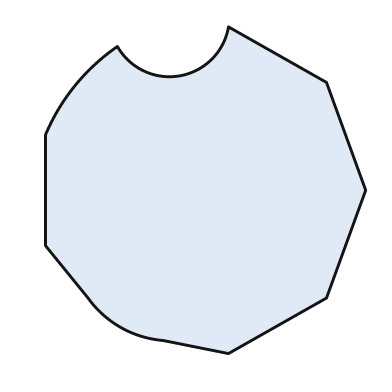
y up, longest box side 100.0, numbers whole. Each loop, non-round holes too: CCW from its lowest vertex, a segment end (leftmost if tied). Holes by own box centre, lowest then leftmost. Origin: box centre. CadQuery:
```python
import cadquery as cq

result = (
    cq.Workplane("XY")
    .moveTo(7.0, -50.0)
    .lineTo(37.0, -33.0)
    .lineTo(49.0, 0.0)
    .lineTo(37.0, 33.0)
    .lineTo(7.0, 50.0)
    .threePointArc((-8.0, 35.0), (-27.0, 44.0))
    .threePointArc((-40.0, 32.0), (-49.0, 17.0))
    .lineTo(-49.0, -17.0)
    .lineTo(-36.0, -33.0)
    .threePointArc((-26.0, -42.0), (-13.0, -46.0))
    .close()
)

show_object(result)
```